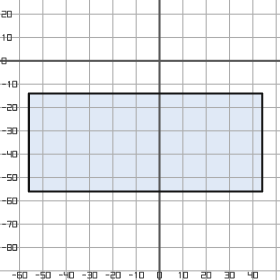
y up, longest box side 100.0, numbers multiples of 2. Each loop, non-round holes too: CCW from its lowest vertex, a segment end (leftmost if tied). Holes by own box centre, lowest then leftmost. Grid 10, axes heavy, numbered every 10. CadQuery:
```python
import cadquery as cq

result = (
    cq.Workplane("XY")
    .moveTo(-56.0, -56.0)
    .lineTo(44.0, -56.0)
    .lineTo(44.0, -14.0)
    .lineTo(-56.0, -14.0)
    .close()
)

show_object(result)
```